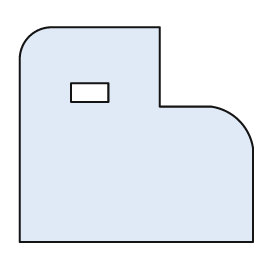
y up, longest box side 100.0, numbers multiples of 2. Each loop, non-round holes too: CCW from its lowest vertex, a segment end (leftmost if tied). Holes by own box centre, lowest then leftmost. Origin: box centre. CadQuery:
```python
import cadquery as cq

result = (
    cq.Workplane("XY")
    .moveTo(-50.0, -46.0)
    .lineTo(50.0, -46.0)
    .lineTo(50.0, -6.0)
    .threePointArc((44.0, 6.0), (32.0, 12.0))
    .lineTo(10.0, 12.0)
    .lineTo(10.0, 46.0)
    .lineTo(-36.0, 46.0)
    .threePointArc((-46.0, 42.0), (-50.0, 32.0))
    .close()
    .moveTo(-28.0, 14.0)
    .lineTo(-12.0, 14.0)
    .lineTo(-12.0, 22.0)
    .lineTo(-28.0, 22.0)
    .close()
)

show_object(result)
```